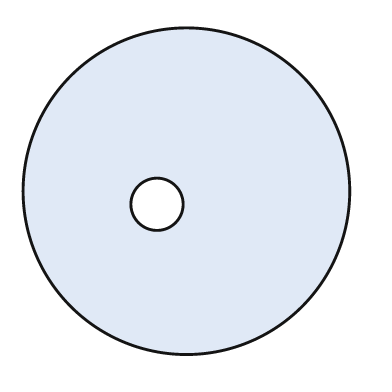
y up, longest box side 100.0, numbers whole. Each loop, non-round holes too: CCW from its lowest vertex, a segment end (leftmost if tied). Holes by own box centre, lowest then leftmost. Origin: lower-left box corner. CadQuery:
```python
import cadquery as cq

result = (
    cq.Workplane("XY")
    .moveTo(50.0, 50.0)
    .circle(50.0)
    .moveTo(41.0, 46.0)
    .circle(8.0)
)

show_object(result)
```